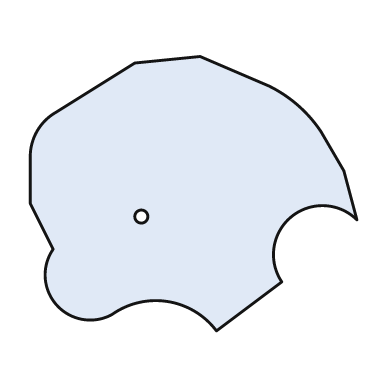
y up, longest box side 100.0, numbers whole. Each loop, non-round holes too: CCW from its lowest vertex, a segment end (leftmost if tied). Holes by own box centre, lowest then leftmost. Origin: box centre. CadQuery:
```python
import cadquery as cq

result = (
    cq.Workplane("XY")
    .moveTo(7.0, -42.0)
    .lineTo(27.0, -27.0)
    .threePointArc((30.0, -7.0), (50.0, -8.0))
    .lineTo(46.0, 7.0)
    .lineTo(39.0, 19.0)
    .threePointArc((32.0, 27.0), (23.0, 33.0))
    .lineTo(2.0, 42.0)
    .lineTo(-18.0, 40.0)
    .lineTo(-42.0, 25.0)
    .threePointArc((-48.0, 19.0), (-50.0, 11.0))
    .lineTo(-50.0, -3.0)
    .lineTo(-43.0, -17.0)
    .threePointArc((-42.0, -34.0), (-25.0, -37.0))
    .threePointArc((-8.0, -33.0), (7.0, -42.0))
    .close()
    .moveTo(-16.0, -7.0)
    .circle(2.0)
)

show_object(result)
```